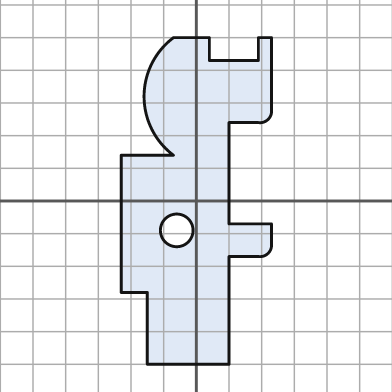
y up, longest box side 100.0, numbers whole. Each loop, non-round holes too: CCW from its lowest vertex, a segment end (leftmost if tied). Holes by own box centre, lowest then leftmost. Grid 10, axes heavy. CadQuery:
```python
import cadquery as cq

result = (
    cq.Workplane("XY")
    .moveTo(-15.0, -50.0)
    .lineTo(10.0, -50.0)
    .lineTo(10.0, -17.0)
    .lineTo(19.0, -17.0)
    .threePointArc((22.0, -16.0), (23.0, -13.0))
    .lineTo(23.0, -7.0)
    .lineTo(10.0, -7.0)
    .lineTo(10.0, 24.0)
    .lineTo(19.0, 24.0)
    .threePointArc((22.0, 25.0), (23.0, 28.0))
    .lineTo(23.0, 50.0)
    .lineTo(19.0, 50.0)
    .lineTo(19.0, 43.0)
    .lineTo(4.0, 43.0)
    .lineTo(4.0, 50.0)
    .lineTo(-7.0, 50.0)
    .threePointArc((-16.0, 32.0), (-7.0, 14.0))
    .lineTo(-23.0, 14.0)
    .lineTo(-23.0, -28.0)
    .lineTo(-15.0, -28.0)
    .close()
    .moveTo(-6.0, -9.0)
    .circle(5.0)
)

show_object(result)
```